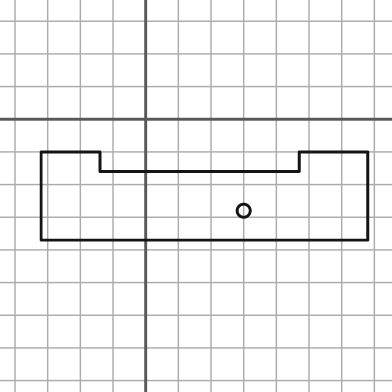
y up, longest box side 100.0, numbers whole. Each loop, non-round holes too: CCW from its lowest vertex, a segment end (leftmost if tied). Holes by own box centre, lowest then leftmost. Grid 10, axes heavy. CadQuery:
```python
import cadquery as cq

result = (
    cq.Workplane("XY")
    .moveTo(-32.0, -37.0)
    .lineTo(68.0, -37.0)
    .lineTo(68.0, -10.0)
    .lineTo(47.0, -10.0)
    .lineTo(47.0, -16.0)
    .lineTo(-14.0, -16.0)
    .lineTo(-14.0, -10.0)
    .lineTo(-32.0, -10.0)
    .close()
    .moveTo(30.0, -28.0)
    .circle(2.0)
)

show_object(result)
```